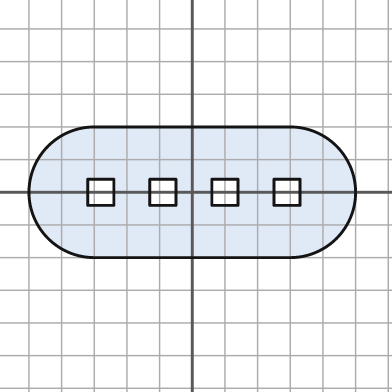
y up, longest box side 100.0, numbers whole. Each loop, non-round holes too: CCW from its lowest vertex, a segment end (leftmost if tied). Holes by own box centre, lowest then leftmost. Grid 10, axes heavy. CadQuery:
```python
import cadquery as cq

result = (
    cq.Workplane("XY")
    .moveTo(-30.0, -20.0)
    .lineTo(30.0, -20.0)
    .threePointArc((50.0, 0.0), (30.0, 20.0))
    .lineTo(-30.0, 20.0)
    .threePointArc((-50.0, 0.0), (-30.0, -20.0))
    .close()
    .moveTo(-32.0, -4.0)
    .lineTo(-24.0, -4.0)
    .lineTo(-24.0, 4.0)
    .lineTo(-32.0, 4.0)
    .close()
    .moveTo(-13.0, -4.0)
    .lineTo(-5.0, -4.0)
    .lineTo(-5.0, 4.0)
    .lineTo(-13.0, 4.0)
    .close()
    .moveTo(6.0, -4.0)
    .lineTo(14.0, -4.0)
    .lineTo(14.0, 4.0)
    .lineTo(6.0, 4.0)
    .close()
    .moveTo(25.0, -4.0)
    .lineTo(33.0, -4.0)
    .lineTo(33.0, 4.0)
    .lineTo(25.0, 4.0)
    .close()
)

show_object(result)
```